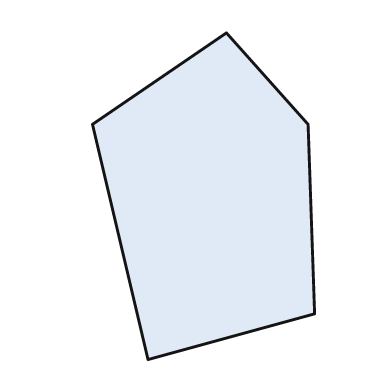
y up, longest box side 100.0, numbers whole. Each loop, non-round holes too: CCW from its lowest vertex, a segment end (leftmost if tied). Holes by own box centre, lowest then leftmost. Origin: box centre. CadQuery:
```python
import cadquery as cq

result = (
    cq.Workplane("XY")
    .moveTo(-17.0, -50.0)
    .lineTo(34.0, -36.0)
    .lineTo(32.0, 22.0)
    .lineTo(7.0, 50.0)
    .lineTo(-34.0, 22.0)
    .close()
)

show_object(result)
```